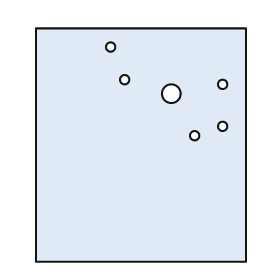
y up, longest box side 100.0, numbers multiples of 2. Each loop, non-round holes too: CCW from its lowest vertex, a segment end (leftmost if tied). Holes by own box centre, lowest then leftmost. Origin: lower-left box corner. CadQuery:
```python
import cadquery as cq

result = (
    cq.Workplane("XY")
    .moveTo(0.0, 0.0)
    .lineTo(90.0, 0.0)
    .lineTo(90.0, 100.0)
    .lineTo(0.0, 100.0)
    .close()
    .moveTo(68.0, 54.0)
    .circle(2.0)
    .moveTo(80.0, 58.0)
    .circle(2.0)
    .moveTo(58.0, 72.0)
    .circle(4.0)
    .moveTo(80.0, 76.0)
    .circle(2.0)
    .moveTo(38.0, 78.0)
    .circle(2.0)
    .moveTo(32.0, 92.0)
    .circle(2.0)
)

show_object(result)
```